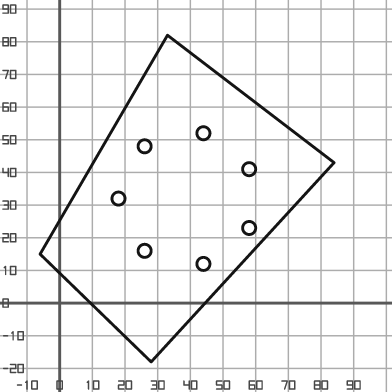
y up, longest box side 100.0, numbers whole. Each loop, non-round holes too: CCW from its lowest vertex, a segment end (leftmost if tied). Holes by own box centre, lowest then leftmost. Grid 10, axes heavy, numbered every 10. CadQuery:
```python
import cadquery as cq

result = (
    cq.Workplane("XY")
    .moveTo(28.0, -18.0)
    .lineTo(84.0, 43.0)
    .lineTo(33.0, 82.0)
    .lineTo(-6.0, 15.0)
    .close()
    .moveTo(44.0, 12.0)
    .circle(2.0)
    .moveTo(26.0, 16.0)
    .circle(2.0)
    .moveTo(58.0, 23.0)
    .circle(2.0)
    .moveTo(18.0, 32.0)
    .circle(2.0)
    .moveTo(58.0, 41.0)
    .circle(2.0)
    .moveTo(26.0, 48.0)
    .circle(2.0)
    .moveTo(44.0, 52.0)
    .circle(2.0)
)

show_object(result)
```